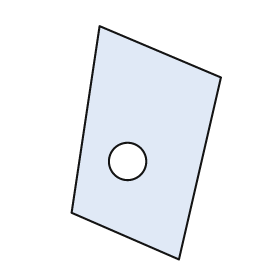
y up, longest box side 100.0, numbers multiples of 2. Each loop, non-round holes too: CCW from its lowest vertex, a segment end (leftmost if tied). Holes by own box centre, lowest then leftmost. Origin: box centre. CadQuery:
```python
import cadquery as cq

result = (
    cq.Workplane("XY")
    .moveTo(14.0, -50.0)
    .lineTo(32.0, 28.0)
    .lineTo(-20.0, 50.0)
    .lineTo(-32.0, -30.0)
    .close()
    .moveTo(-8.0, -8.0)
    .circle(8.0)
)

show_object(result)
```